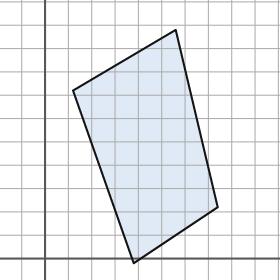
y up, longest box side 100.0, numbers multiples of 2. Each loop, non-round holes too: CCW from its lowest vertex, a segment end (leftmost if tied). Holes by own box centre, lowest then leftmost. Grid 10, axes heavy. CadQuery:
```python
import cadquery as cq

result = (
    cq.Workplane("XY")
    .moveTo(38.0, -2.0)
    .lineTo(74.0, 22.0)
    .lineTo(56.0, 98.0)
    .lineTo(12.0, 72.0)
    .close()
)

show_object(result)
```